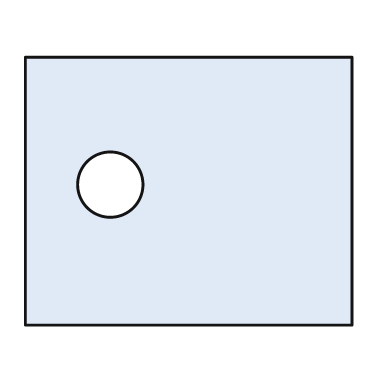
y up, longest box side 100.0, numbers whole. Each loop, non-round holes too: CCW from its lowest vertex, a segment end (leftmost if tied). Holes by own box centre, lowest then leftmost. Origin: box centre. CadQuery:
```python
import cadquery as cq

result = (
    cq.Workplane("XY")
    .moveTo(-50.0, -41.0)
    .lineTo(50.0, -41.0)
    .lineTo(50.0, 41.0)
    .lineTo(-50.0, 41.0)
    .close()
    .moveTo(-24.0, 2.0)
    .circle(10.0)
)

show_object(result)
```